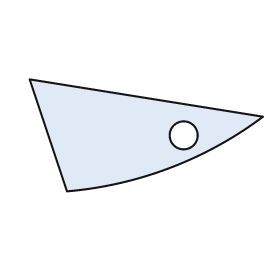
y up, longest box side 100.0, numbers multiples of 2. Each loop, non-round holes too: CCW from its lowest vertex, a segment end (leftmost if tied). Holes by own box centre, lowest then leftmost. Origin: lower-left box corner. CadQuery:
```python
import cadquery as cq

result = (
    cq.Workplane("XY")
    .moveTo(16.0, 0.0)
    .threePointArc((60.0, 10.0), (100.0, 32.0))
    .lineTo(0.0, 48.0)
    .close()
    .moveTo(66.0, 24.0)
    .circle(6.0)
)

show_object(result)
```